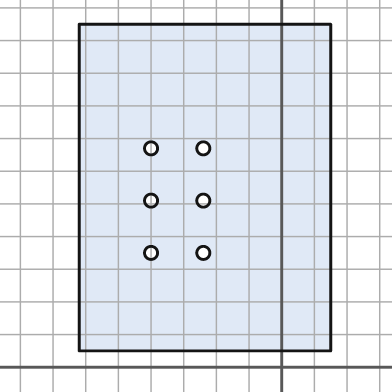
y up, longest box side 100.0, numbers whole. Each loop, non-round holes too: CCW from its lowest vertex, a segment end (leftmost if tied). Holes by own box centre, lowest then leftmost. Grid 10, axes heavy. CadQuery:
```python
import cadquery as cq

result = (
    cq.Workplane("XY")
    .moveTo(-62.0, 5.0)
    .lineTo(15.0, 5.0)
    .lineTo(15.0, 105.0)
    .lineTo(-62.0, 105.0)
    .close()
    .moveTo(-40.0, 35.0)
    .circle(2.0)
    .moveTo(-24.0, 35.0)
    .circle(2.0)
    .moveTo(-40.0, 51.0)
    .circle(2.0)
    .moveTo(-24.0, 51.0)
    .circle(2.0)
    .moveTo(-40.0, 67.0)
    .circle(2.0)
    .moveTo(-24.0, 67.0)
    .circle(2.0)
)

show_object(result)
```